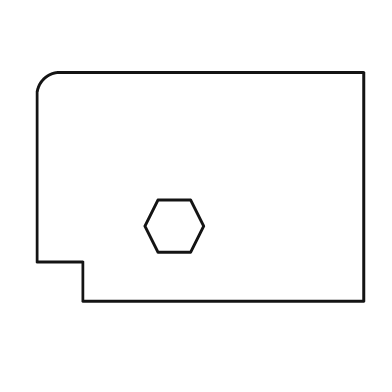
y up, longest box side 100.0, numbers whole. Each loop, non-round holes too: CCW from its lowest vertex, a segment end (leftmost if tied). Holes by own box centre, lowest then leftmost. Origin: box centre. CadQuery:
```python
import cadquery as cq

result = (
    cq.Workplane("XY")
    .moveTo(-36.0, -35.0)
    .lineTo(50.0, -35.0)
    .lineTo(50.0, 35.0)
    .lineTo(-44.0, 35.0)
    .threePointArc((-48.0, 33.0), (-50.0, 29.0))
    .lineTo(-50.0, -23.0)
    .lineTo(-36.0, -23.0)
    .close()
    .moveTo(-13.0, -20.0)
    .lineTo(-3.0, -20.0)
    .lineTo(1.0, -12.0)
    .lineTo(-3.0, -4.0)
    .lineTo(-13.0, -4.0)
    .lineTo(-17.0, -12.0)
    .close()
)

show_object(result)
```